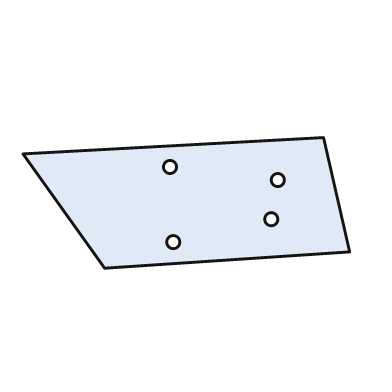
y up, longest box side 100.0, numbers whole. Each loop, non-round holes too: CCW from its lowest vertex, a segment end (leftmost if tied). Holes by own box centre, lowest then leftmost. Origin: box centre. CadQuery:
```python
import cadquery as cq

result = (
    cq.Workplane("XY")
    .moveTo(-25.0, -20.0)
    .lineTo(50.0, -15.0)
    .lineTo(42.0, 20.0)
    .lineTo(-50.0, 15.0)
    .close()
    .moveTo(-4.0, -12.0)
    .circle(2.0)
    .moveTo(26.0, -5.0)
    .circle(2.0)
    .moveTo(28.0, 7.0)
    .circle(2.0)
    .moveTo(-5.0, 11.0)
    .circle(2.0)
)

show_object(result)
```